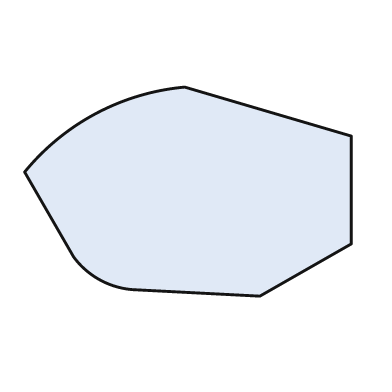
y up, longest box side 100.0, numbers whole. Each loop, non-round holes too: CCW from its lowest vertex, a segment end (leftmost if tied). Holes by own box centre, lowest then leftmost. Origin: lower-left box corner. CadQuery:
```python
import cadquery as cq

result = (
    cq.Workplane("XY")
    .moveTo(72.0, 0.0)
    .lineTo(100.0, 16.0)
    .lineTo(100.0, 49.0)
    .lineTo(49.0, 64.0)
    .threePointArc((22.0, 56.0), (0.0, 38.0))
    .lineTo(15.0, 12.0)
    .threePointArc((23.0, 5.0), (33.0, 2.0))
    .close()
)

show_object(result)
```